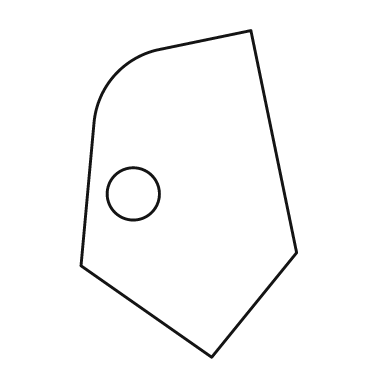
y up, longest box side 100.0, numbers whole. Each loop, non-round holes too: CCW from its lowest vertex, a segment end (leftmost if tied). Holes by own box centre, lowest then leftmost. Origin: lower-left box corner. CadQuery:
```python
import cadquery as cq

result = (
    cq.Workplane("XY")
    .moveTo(40.0, 0.0)
    .lineTo(66.0, 32.0)
    .lineTo(52.0, 100.0)
    .lineTo(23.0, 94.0)
    .threePointArc((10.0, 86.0), (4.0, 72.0))
    .lineTo(0.0, 28.0)
    .close()
    .moveTo(16.0, 50.0)
    .circle(8.0)
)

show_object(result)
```